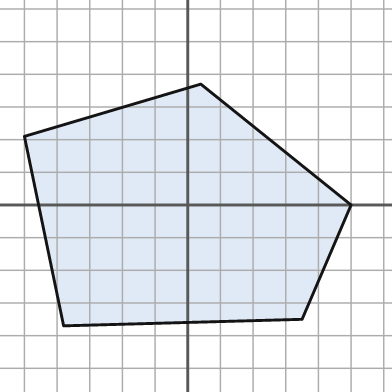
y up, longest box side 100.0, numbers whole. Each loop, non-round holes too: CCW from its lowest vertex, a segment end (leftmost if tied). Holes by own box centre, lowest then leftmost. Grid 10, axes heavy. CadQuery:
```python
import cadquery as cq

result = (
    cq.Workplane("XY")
    .moveTo(-38.0, -37.0)
    .lineTo(35.0, -35.0)
    .lineTo(50.0, 0.0)
    .lineTo(4.0, 37.0)
    .lineTo(-50.0, 21.0)
    .close()
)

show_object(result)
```